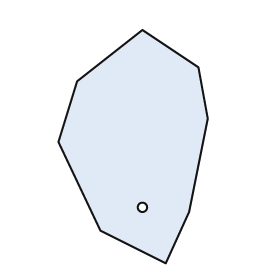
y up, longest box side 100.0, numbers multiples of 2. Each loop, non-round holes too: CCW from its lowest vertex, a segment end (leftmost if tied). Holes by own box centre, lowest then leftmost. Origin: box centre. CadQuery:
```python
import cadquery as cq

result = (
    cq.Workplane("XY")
    .moveTo(14.0, -50.0)
    .lineTo(24.0, -28.0)
    .lineTo(32.0, 12.0)
    .lineTo(28.0, 34.0)
    .lineTo(4.0, 50.0)
    .lineTo(-24.0, 28.0)
    .lineTo(-32.0, 2.0)
    .lineTo(-14.0, -36.0)
    .close()
    .moveTo(4.0, -26.0)
    .circle(2.0)
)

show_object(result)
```